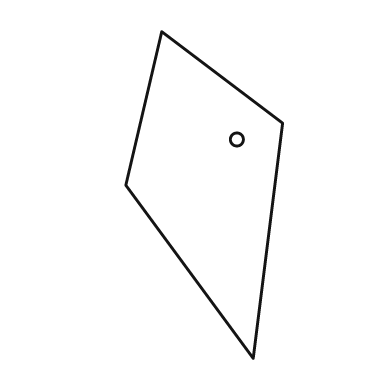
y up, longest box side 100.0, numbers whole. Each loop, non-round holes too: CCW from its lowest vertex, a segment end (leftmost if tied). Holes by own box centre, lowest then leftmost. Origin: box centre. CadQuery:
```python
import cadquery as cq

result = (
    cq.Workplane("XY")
    .moveTo(15.0, -50.0)
    .lineTo(24.0, 22.0)
    .lineTo(-13.0, 50.0)
    .lineTo(-24.0, 3.0)
    .close()
    .moveTo(10.0, 17.0)
    .circle(2.0)
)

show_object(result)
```